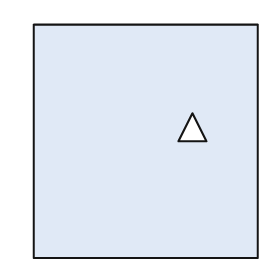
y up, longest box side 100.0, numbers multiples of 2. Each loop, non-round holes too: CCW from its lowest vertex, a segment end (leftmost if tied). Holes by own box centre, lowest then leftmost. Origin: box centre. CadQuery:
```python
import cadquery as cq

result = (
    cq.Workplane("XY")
    .moveTo(-48.0, -50.0)
    .lineTo(48.0, -50.0)
    .lineTo(48.0, 50.0)
    .lineTo(-48.0, 50.0)
    .close()
    .moveTo(14.0, 0.0)
    .lineTo(26.0, 0.0)
    .lineTo(20.0, 12.0)
    .close()
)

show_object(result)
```